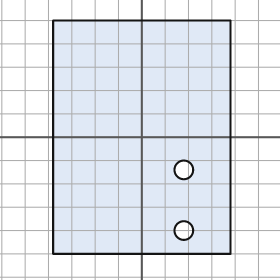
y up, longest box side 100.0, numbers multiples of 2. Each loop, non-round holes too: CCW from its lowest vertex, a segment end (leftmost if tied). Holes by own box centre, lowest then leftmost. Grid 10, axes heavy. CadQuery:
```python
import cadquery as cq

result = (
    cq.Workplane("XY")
    .moveTo(-38.0, -50.0)
    .lineTo(38.0, -50.0)
    .lineTo(38.0, 50.0)
    .lineTo(-38.0, 50.0)
    .close()
    .moveTo(18.0, -40.0)
    .circle(4.0)
    .moveTo(18.0, -14.0)
    .circle(4.0)
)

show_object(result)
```